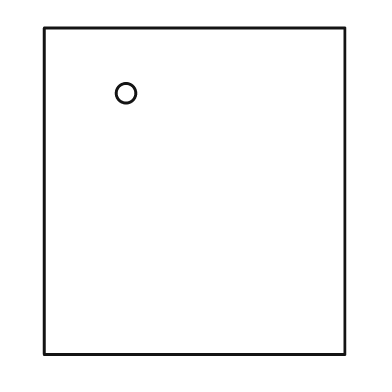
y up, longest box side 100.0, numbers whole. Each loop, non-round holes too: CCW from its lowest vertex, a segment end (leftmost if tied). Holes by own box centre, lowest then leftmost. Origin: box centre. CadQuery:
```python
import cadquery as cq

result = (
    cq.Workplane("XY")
    .moveTo(-46.0, -50.0)
    .lineTo(46.0, -50.0)
    .lineTo(46.0, 50.0)
    .lineTo(-46.0, 50.0)
    .close()
    .moveTo(-21.0, 30.0)
    .circle(3.0)
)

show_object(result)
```